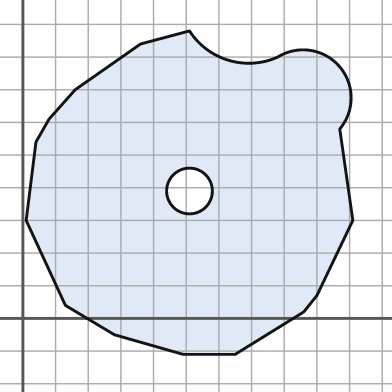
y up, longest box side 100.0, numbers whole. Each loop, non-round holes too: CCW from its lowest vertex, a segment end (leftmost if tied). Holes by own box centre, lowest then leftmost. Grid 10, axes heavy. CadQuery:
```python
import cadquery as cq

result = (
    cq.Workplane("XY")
    .moveTo(49.0, -11.0)
    .lineTo(65.0, -11.0)
    .lineTo(86.0, 2.0)
    .lineTo(90.0, 7.0)
    .lineTo(101.0, 30.0)
    .lineTo(97.0, 58.0)
    .threePointArc((97.0, 77.0), (78.0, 80.0))
    .threePointArc((63.0, 79.0), (51.0, 88.0))
    .lineTo(36.0, 84.0)
    .lineTo(16.0, 70.0)
    .lineTo(8.0, 61.0)
    .lineTo(4.0, 54.0)
    .lineTo(1.0, 30.0)
    .lineTo(13.0, 4.0)
    .lineTo(28.0, -5.0)
    .close()
    .moveTo(51.0, 39.0)
    .circle(7.0)
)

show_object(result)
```